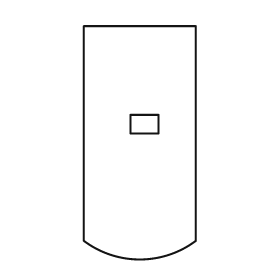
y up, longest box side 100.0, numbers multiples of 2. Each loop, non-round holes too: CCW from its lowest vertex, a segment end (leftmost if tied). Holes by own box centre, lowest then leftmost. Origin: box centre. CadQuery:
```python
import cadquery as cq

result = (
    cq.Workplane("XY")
    .moveTo(-24.0, -42.0)
    .threePointArc((0.0, -50.0), (24.0, -42.0))
    .lineTo(24.0, 50.0)
    .lineTo(-24.0, 50.0)
    .close()
    .moveTo(-4.0, 4.0)
    .lineTo(8.0, 4.0)
    .lineTo(8.0, 12.0)
    .lineTo(-4.0, 12.0)
    .close()
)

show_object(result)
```